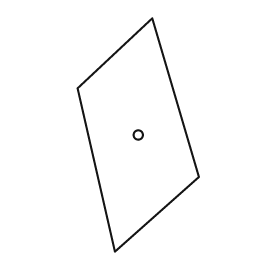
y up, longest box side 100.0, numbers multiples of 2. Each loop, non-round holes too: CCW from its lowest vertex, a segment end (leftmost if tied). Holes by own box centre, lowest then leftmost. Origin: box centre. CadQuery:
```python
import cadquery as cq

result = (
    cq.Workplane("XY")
    .moveTo(-10.0, -50.0)
    .lineTo(26.0, -18.0)
    .lineTo(6.0, 50.0)
    .lineTo(-26.0, 20.0)
    .close()
    .moveTo(0.0, 0.0)
    .circle(2.0)
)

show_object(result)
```